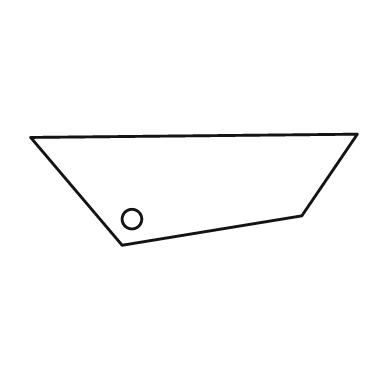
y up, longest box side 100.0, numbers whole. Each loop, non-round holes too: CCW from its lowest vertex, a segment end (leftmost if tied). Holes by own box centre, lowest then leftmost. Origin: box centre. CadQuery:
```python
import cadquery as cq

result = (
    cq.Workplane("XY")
    .moveTo(-22.0, -17.0)
    .lineTo(33.0, -8.0)
    .lineTo(50.0, 17.0)
    .lineTo(-50.0, 16.0)
    .close()
    .moveTo(-19.0, -9.0)
    .circle(3.0)
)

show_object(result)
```